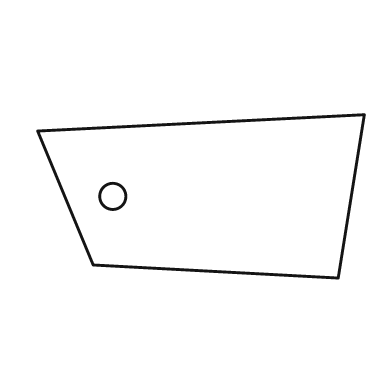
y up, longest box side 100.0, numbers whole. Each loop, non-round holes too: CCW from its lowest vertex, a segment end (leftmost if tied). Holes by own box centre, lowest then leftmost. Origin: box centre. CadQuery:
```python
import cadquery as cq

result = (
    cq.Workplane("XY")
    .moveTo(42.0, -25.0)
    .lineTo(50.0, 25.0)
    .lineTo(-50.0, 20.0)
    .lineTo(-33.0, -21.0)
    .close()
    .moveTo(-27.0, 0.0)
    .circle(4.0)
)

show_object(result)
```